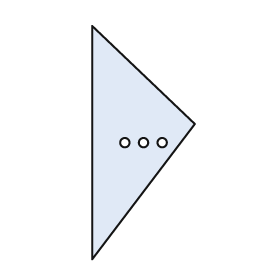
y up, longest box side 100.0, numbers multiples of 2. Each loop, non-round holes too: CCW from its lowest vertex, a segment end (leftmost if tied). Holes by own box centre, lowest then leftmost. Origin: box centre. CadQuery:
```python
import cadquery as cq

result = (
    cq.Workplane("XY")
    .moveTo(-22.0, -50.0)
    .lineTo(22.0, 8.0)
    .lineTo(-22.0, 50.0)
    .close()
    .moveTo(-8.0, 0.0)
    .circle(2.0)
    .moveTo(0.0, 0.0)
    .circle(2.0)
    .moveTo(8.0, 0.0)
    .circle(2.0)
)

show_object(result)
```